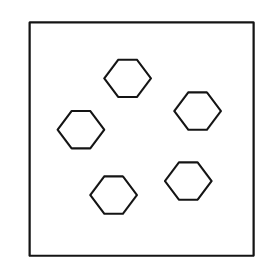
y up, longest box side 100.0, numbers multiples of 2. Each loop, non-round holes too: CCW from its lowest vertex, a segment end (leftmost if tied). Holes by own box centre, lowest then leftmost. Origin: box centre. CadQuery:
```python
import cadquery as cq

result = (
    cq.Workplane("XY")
    .moveTo(-48.0, -50.0)
    .lineTo(48.0, -50.0)
    .lineTo(48.0, 50.0)
    .lineTo(-48.0, 50.0)
    .close()
    .moveTo(-16.0, -32.0)
    .lineTo(-8.0, -32.0)
    .lineTo(-2.0, -24.0)
    .lineTo(-8.0, -16.0)
    .lineTo(-16.0, -16.0)
    .lineTo(-22.0, -24.0)
    .close()
    .moveTo(16.0, -26.0)
    .lineTo(24.0, -26.0)
    .lineTo(30.0, -18.0)
    .lineTo(24.0, -10.0)
    .lineTo(16.0, -10.0)
    .lineTo(10.0, -18.0)
    .close()
    .moveTo(-30.0, -4.0)
    .lineTo(-22.0, -4.0)
    .lineTo(-16.0, 4.0)
    .lineTo(-22.0, 12.0)
    .lineTo(-30.0, 12.0)
    .lineTo(-36.0, 4.0)
    .close()
    .moveTo(20.0, 4.0)
    .lineTo(28.0, 4.0)
    .lineTo(34.0, 12.0)
    .lineTo(28.0, 20.0)
    .lineTo(20.0, 20.0)
    .lineTo(14.0, 12.0)
    .close()
    .moveTo(-10.0, 18.0)
    .lineTo(-2.0, 18.0)
    .lineTo(4.0, 26.0)
    .lineTo(-2.0, 34.0)
    .lineTo(-10.0, 34.0)
    .lineTo(-16.0, 26.0)
    .close()
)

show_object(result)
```